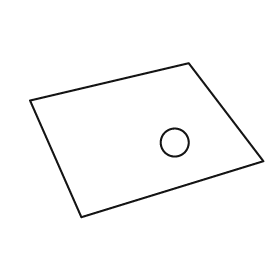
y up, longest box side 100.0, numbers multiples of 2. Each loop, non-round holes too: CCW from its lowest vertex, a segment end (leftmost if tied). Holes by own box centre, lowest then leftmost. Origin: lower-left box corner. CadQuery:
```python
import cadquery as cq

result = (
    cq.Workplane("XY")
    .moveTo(22.0, 0.0)
    .lineTo(100.0, 24.0)
    .lineTo(68.0, 66.0)
    .lineTo(0.0, 50.0)
    .close()
    .moveTo(62.0, 32.0)
    .circle(6.0)
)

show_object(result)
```